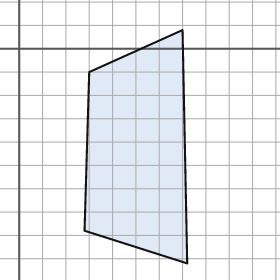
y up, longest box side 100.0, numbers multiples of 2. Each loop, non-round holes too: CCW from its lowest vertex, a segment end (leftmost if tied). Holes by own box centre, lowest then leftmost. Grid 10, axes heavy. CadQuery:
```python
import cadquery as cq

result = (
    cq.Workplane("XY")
    .moveTo(72.0, -92.0)
    .lineTo(70.0, 8.0)
    .lineTo(30.0, -10.0)
    .lineTo(28.0, -78.0)
    .close()
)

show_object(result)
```